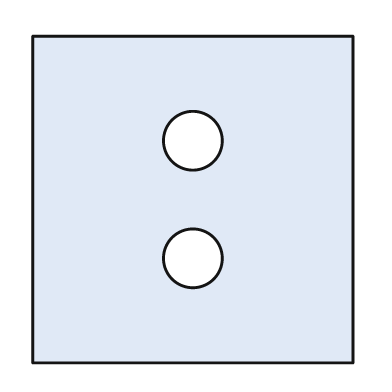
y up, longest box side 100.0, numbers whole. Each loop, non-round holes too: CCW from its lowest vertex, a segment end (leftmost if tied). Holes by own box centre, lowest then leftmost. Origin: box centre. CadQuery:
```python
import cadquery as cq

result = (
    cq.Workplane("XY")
    .moveTo(-49.0, -50.0)
    .lineTo(49.0, -50.0)
    .lineTo(49.0, 50.0)
    .lineTo(-49.0, 50.0)
    .close()
    .moveTo(0.0, -18.0)
    .circle(9.0)
    .moveTo(0.0, 18.0)
    .circle(9.0)
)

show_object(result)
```